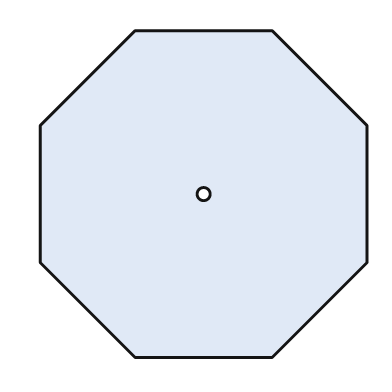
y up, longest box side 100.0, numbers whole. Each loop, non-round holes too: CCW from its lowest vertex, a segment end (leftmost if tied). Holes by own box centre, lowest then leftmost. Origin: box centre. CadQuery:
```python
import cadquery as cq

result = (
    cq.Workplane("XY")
    .moveTo(-21.0, -50.0)
    .lineTo(21.0, -50.0)
    .lineTo(50.0, -21.0)
    .lineTo(50.0, 21.0)
    .lineTo(21.0, 50.0)
    .lineTo(-21.0, 50.0)
    .lineTo(-50.0, 21.0)
    .lineTo(-50.0, -21.0)
    .close()
    .moveTo(0.0, 0.0)
    .circle(2.0)
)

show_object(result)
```